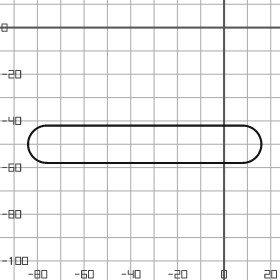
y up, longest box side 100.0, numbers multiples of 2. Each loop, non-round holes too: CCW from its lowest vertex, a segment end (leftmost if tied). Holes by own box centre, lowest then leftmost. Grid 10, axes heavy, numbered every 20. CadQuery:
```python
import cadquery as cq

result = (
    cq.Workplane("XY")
    .moveTo(-76.0, -58.0)
    .lineTo(8.0, -58.0)
    .threePointArc((16.0, -50.0), (8.0, -42.0))
    .lineTo(-76.0, -42.0)
    .threePointArc((-84.0, -50.0), (-76.0, -58.0))
    .close()
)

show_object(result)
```